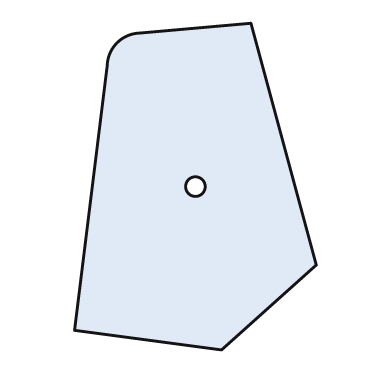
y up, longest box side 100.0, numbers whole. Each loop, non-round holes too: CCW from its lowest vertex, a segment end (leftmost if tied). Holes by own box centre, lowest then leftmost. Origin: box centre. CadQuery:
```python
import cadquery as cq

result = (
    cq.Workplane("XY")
    .moveTo(8.0, -50.0)
    .lineTo(37.0, -24.0)
    .lineTo(17.0, 50.0)
    .lineTo(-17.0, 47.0)
    .threePointArc((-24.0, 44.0), (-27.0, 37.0))
    .lineTo(-37.0, -44.0)
    .close()
    .moveTo(0.0, 0.0)
    .circle(3.0)
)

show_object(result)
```